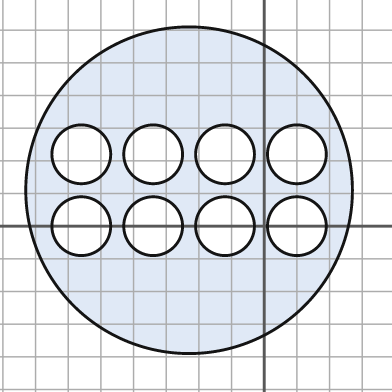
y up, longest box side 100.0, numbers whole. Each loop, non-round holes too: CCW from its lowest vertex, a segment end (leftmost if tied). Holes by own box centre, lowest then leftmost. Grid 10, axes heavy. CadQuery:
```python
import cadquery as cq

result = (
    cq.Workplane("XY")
    .moveTo(-23.0, 11.0)
    .circle(50.0)
    .moveTo(-56.0, 0.0)
    .circle(9.0)
    .moveTo(-34.0, 0.0)
    .circle(9.0)
    .moveTo(-12.0, 0.0)
    .circle(9.0)
    .moveTo(10.0, 0.0)
    .circle(9.0)
    .moveTo(-56.0, 22.0)
    .circle(9.0)
    .moveTo(-34.0, 22.0)
    .circle(9.0)
    .moveTo(-12.0, 22.0)
    .circle(9.0)
    .moveTo(10.0, 22.0)
    .circle(9.0)
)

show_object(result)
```